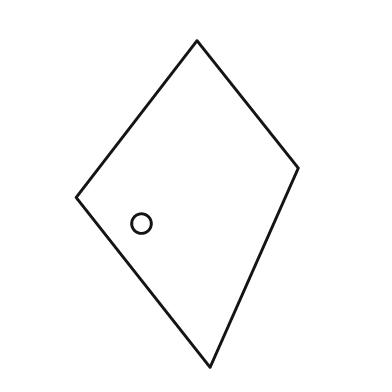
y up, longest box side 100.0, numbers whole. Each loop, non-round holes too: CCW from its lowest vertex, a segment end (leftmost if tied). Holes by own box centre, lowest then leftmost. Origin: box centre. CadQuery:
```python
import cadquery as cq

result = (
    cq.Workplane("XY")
    .moveTo(7.0, -50.0)
    .lineTo(34.0, 11.0)
    .lineTo(3.0, 50.0)
    .lineTo(-34.0, 2.0)
    .close()
    .moveTo(-14.0, -6.0)
    .circle(3.0)
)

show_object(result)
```